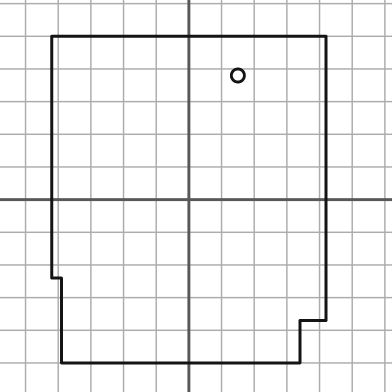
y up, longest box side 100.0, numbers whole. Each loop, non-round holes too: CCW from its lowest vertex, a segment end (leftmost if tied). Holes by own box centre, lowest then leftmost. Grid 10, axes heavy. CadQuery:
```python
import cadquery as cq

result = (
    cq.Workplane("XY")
    .moveTo(-39.0, -50.0)
    .lineTo(34.0, -50.0)
    .lineTo(34.0, -37.0)
    .lineTo(42.0, -37.0)
    .lineTo(42.0, 50.0)
    .lineTo(-42.0, 50.0)
    .lineTo(-42.0, -24.0)
    .lineTo(-39.0, -24.0)
    .close()
    .moveTo(15.0, 38.0)
    .circle(2.0)
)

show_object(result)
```